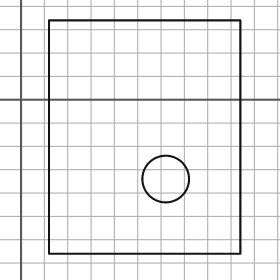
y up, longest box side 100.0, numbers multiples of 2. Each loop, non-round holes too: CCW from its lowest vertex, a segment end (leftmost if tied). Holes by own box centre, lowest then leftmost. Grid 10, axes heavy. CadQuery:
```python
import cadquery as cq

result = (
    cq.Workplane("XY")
    .moveTo(12.0, -66.0)
    .lineTo(94.0, -66.0)
    .lineTo(94.0, 34.0)
    .lineTo(12.0, 34.0)
    .close()
    .moveTo(62.0, -34.0)
    .circle(10.0)
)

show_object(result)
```